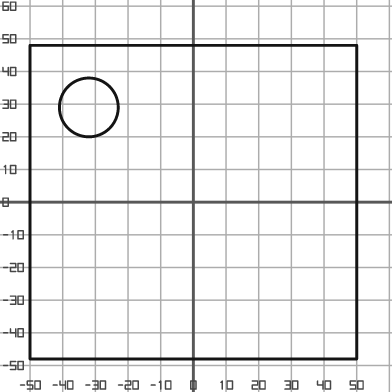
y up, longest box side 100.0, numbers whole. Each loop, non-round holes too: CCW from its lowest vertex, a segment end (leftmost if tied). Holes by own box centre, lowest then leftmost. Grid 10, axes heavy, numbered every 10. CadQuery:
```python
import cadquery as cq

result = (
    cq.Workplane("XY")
    .moveTo(-50.0, -48.0)
    .lineTo(50.0, -48.0)
    .lineTo(50.0, 48.0)
    .lineTo(-50.0, 48.0)
    .close()
    .moveTo(-32.0, 29.0)
    .circle(9.0)
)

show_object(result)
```